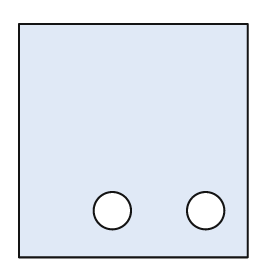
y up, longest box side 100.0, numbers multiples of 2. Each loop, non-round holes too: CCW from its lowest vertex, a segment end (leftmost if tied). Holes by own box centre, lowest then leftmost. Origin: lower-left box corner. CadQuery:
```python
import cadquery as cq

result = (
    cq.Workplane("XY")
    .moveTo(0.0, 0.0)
    .lineTo(98.0, 0.0)
    .lineTo(98.0, 100.0)
    .lineTo(0.0, 100.0)
    .close()
    .moveTo(40.0, 20.0)
    .circle(8.0)
    .moveTo(80.0, 20.0)
    .circle(8.0)
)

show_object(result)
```